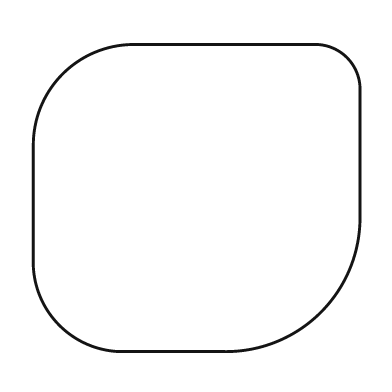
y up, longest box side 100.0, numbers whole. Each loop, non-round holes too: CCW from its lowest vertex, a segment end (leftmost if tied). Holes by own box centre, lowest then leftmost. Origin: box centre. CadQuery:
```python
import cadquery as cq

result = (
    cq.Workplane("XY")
    .moveTo(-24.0, -47.0)
    .lineTo(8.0, -47.0)
    .threePointArc((38.0, -35.0), (50.0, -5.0))
    .lineTo(50.0, 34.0)
    .threePointArc((46.0, 43.0), (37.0, 47.0))
    .lineTo(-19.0, 47.0)
    .threePointArc((-41.0, 38.0), (-50.0, 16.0))
    .lineTo(-50.0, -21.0)
    .threePointArc((-42.0, -39.0), (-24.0, -47.0))
    .close()
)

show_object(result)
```